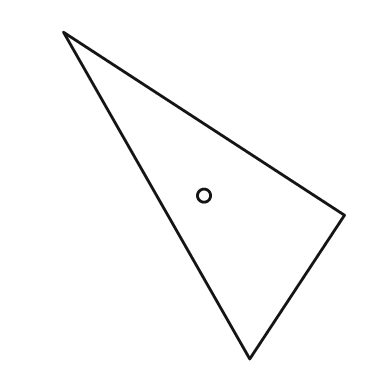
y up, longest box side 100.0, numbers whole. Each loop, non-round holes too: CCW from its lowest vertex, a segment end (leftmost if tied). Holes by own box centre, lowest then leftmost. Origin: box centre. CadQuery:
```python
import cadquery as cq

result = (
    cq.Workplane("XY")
    .moveTo(14.0, -50.0)
    .lineTo(43.0, -6.0)
    .lineTo(-43.0, 50.0)
    .close()
    .moveTo(0.0, 0.0)
    .circle(2.0)
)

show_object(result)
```